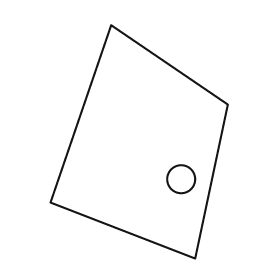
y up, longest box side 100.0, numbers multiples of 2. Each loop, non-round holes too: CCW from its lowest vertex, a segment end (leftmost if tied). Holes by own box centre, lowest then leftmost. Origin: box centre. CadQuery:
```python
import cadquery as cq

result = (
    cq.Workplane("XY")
    .moveTo(24.0, -50.0)
    .lineTo(38.0, 16.0)
    .lineTo(-12.0, 50.0)
    .lineTo(-38.0, -26.0)
    .close()
    .moveTo(18.0, -16.0)
    .circle(6.0)
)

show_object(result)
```